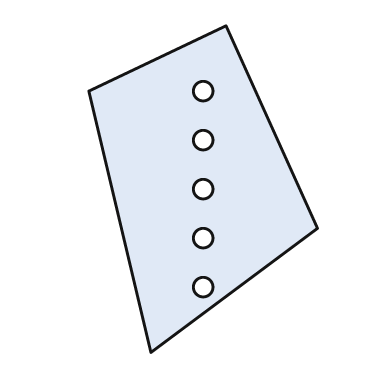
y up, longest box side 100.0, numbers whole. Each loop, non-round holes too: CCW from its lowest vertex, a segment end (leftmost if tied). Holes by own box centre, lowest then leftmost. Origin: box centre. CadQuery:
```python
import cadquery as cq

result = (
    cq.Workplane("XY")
    .moveTo(-16.0, -50.0)
    .lineTo(35.0, -12.0)
    .lineTo(7.0, 50.0)
    .lineTo(-35.0, 30.0)
    .close()
    .moveTo(0.0, -30.0)
    .circle(3.0)
    .moveTo(0.0, -15.0)
    .circle(3.0)
    .moveTo(0.0, 0.0)
    .circle(3.0)
    .moveTo(0.0, 15.0)
    .circle(3.0)
    .moveTo(0.0, 30.0)
    .circle(3.0)
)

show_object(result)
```